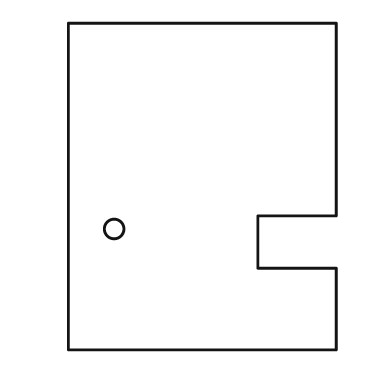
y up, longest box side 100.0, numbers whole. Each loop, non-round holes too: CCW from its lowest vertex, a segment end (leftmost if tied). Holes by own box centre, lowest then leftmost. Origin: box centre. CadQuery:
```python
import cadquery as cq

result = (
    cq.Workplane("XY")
    .moveTo(-41.0, -50.0)
    .lineTo(41.0, -50.0)
    .lineTo(41.0, -25.0)
    .lineTo(17.0, -25.0)
    .lineTo(17.0, -9.0)
    .lineTo(41.0, -9.0)
    .lineTo(41.0, 50.0)
    .lineTo(-41.0, 50.0)
    .close()
    .moveTo(-27.0, -13.0)
    .circle(3.0)
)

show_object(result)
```